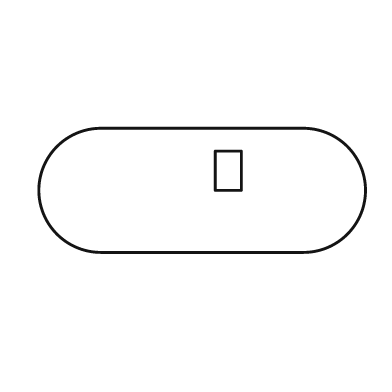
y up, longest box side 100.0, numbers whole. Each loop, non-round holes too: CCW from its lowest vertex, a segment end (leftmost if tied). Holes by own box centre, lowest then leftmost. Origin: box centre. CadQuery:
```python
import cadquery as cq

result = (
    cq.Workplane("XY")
    .moveTo(-31.0, -19.0)
    .lineTo(31.0, -19.0)
    .threePointArc((50.0, 0.0), (31.0, 19.0))
    .lineTo(-31.0, 19.0)
    .threePointArc((-50.0, 0.0), (-31.0, -19.0))
    .close()
    .moveTo(4.0, 0.0)
    .lineTo(12.0, 0.0)
    .lineTo(12.0, 12.0)
    .lineTo(4.0, 12.0)
    .close()
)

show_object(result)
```